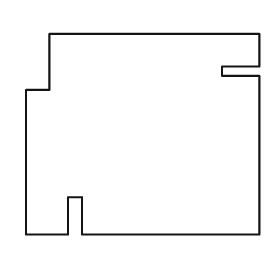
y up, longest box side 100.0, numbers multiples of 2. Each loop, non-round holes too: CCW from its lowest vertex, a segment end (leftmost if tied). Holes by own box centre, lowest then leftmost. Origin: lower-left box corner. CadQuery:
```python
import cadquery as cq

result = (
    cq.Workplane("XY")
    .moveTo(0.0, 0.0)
    .lineTo(18.0, 0.0)
    .lineTo(18.0, 16.0)
    .lineTo(24.0, 16.0)
    .lineTo(24.0, 0.0)
    .lineTo(100.0, 0.0)
    .lineTo(100.0, 68.0)
    .lineTo(84.0, 68.0)
    .lineTo(84.0, 72.0)
    .lineTo(100.0, 72.0)
    .lineTo(100.0, 86.0)
    .lineTo(10.0, 86.0)
    .lineTo(10.0, 62.0)
    .lineTo(0.0, 62.0)
    .close()
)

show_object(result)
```